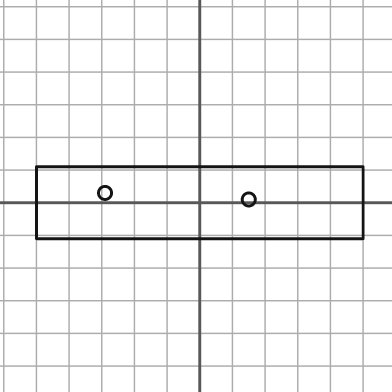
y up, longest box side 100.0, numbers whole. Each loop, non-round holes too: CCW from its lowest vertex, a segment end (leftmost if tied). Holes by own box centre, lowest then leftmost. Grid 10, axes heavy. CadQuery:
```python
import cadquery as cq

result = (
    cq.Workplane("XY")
    .moveTo(-50.0, -11.0)
    .lineTo(50.0, -11.0)
    .lineTo(50.0, 11.0)
    .lineTo(-50.0, 11.0)
    .close()
    .moveTo(15.0, 1.0)
    .circle(2.0)
    .moveTo(-29.0, 3.0)
    .circle(2.0)
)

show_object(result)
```